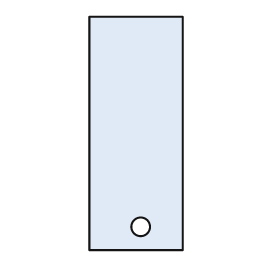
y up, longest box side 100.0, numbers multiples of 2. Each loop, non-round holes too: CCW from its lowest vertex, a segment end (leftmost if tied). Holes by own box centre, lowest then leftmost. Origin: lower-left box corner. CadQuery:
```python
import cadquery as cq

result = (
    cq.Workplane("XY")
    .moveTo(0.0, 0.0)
    .lineTo(40.0, 0.0)
    .lineTo(40.0, 100.0)
    .lineTo(0.0, 100.0)
    .close()
    .moveTo(22.0, 10.0)
    .circle(4.0)
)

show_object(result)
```